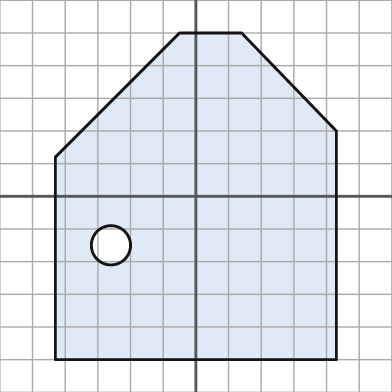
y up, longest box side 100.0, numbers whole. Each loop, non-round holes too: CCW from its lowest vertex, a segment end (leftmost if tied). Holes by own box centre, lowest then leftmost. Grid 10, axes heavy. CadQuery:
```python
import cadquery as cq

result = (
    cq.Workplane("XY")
    .moveTo(-43.0, -50.0)
    .lineTo(43.0, -50.0)
    .lineTo(43.0, 20.0)
    .lineTo(14.0, 50.0)
    .lineTo(-5.0, 50.0)
    .lineTo(-43.0, 12.0)
    .close()
    .moveTo(-26.0, -15.0)
    .circle(6.0)
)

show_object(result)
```